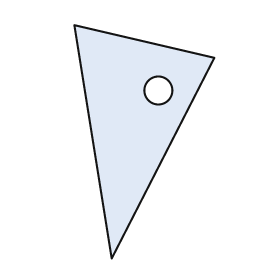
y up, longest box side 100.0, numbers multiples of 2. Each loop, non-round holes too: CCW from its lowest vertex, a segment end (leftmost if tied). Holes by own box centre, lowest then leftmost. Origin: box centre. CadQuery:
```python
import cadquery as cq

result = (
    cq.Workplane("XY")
    .moveTo(-14.0, -50.0)
    .lineTo(30.0, 36.0)
    .lineTo(-30.0, 50.0)
    .close()
    .moveTo(6.0, 22.0)
    .circle(6.0)
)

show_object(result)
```